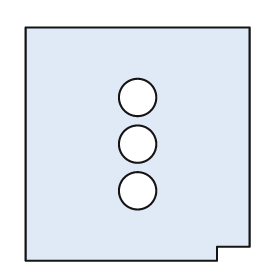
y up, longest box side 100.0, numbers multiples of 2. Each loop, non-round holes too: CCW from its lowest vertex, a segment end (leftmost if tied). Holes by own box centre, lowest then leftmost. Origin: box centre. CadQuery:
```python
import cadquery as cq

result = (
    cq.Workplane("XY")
    .moveTo(-48.0, -50.0)
    .lineTo(34.0, -50.0)
    .lineTo(34.0, -44.0)
    .lineTo(48.0, -44.0)
    .lineTo(48.0, 50.0)
    .lineTo(-48.0, 50.0)
    .close()
    .moveTo(0.0, -20.0)
    .circle(8.0)
    .moveTo(0.0, 0.0)
    .circle(8.0)
    .moveTo(0.0, 20.0)
    .circle(8.0)
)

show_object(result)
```